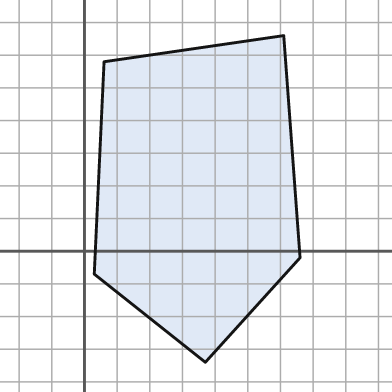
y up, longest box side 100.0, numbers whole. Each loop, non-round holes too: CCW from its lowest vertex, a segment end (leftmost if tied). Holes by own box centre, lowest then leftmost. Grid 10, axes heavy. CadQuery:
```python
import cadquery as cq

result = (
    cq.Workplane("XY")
    .moveTo(37.0, -34.0)
    .lineTo(66.0, -2.0)
    .lineTo(61.0, 66.0)
    .lineTo(6.0, 58.0)
    .lineTo(3.0, -7.0)
    .close()
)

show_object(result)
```